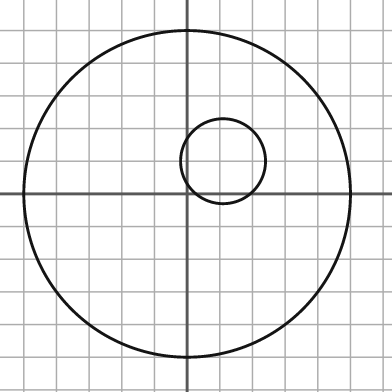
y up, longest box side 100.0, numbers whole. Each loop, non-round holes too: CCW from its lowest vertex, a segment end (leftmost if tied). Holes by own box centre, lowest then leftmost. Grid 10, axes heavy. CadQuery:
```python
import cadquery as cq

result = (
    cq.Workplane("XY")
    .moveTo(0.0, 0.0)
    .circle(50.0)
    .moveTo(11.0, 10.0)
    .circle(13.0)
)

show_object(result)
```